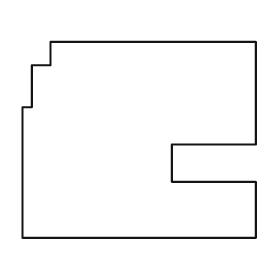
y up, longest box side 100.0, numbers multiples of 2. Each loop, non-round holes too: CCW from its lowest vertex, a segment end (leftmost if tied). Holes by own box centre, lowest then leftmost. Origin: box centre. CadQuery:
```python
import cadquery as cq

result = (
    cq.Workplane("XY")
    .moveTo(-50.0, -42.0)
    .lineTo(50.0, -42.0)
    .lineTo(50.0, -18.0)
    .lineTo(14.0, -18.0)
    .lineTo(14.0, -2.0)
    .lineTo(50.0, -2.0)
    .lineTo(50.0, 42.0)
    .lineTo(-38.0, 42.0)
    .lineTo(-38.0, 32.0)
    .lineTo(-46.0, 32.0)
    .lineTo(-46.0, 14.0)
    .lineTo(-50.0, 14.0)
    .close()
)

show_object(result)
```